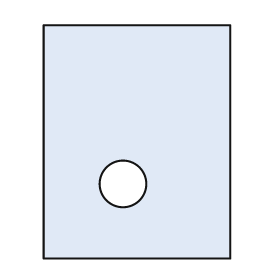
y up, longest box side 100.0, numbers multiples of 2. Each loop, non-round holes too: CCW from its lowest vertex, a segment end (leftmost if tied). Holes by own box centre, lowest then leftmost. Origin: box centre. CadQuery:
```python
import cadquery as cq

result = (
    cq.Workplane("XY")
    .moveTo(-40.0, -50.0)
    .lineTo(40.0, -50.0)
    .lineTo(40.0, 50.0)
    .lineTo(-40.0, 50.0)
    .close()
    .moveTo(-6.0, -18.0)
    .circle(10.0)
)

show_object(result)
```